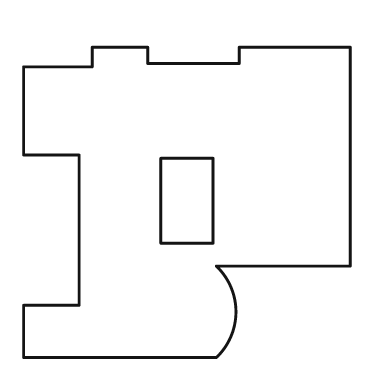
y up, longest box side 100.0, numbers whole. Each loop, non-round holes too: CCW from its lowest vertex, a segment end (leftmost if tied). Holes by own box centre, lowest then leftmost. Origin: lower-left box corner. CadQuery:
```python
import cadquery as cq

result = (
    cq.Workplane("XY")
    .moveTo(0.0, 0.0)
    .lineTo(59.0, 0.0)
    .threePointArc((65.0, 14.0), (59.0, 28.0))
    .lineTo(100.0, 28.0)
    .lineTo(100.0, 95.0)
    .lineTo(66.0, 95.0)
    .lineTo(66.0, 90.0)
    .lineTo(38.0, 90.0)
    .lineTo(38.0, 95.0)
    .lineTo(21.0, 95.0)
    .lineTo(21.0, 89.0)
    .lineTo(0.0, 89.0)
    .lineTo(0.0, 62.0)
    .lineTo(17.0, 62.0)
    .lineTo(17.0, 16.0)
    .lineTo(0.0, 16.0)
    .close()
    .moveTo(42.0, 35.0)
    .lineTo(58.0, 35.0)
    .lineTo(58.0, 61.0)
    .lineTo(42.0, 61.0)
    .close()
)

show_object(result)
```